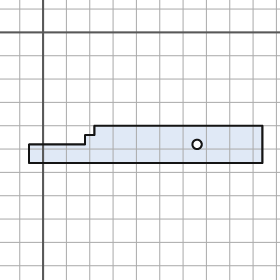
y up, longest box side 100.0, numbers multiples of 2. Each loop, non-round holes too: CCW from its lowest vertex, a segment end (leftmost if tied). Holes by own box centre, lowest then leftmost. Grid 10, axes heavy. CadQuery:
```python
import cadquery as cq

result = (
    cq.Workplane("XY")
    .moveTo(-6.0, -56.0)
    .lineTo(94.0, -56.0)
    .lineTo(94.0, -40.0)
    .lineTo(22.0, -40.0)
    .lineTo(22.0, -44.0)
    .lineTo(18.0, -44.0)
    .lineTo(18.0, -48.0)
    .lineTo(-6.0, -48.0)
    .close()
    .moveTo(66.0, -48.0)
    .circle(2.0)
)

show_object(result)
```